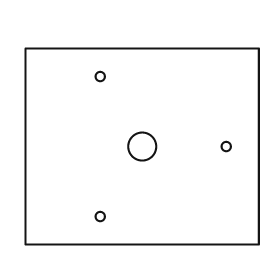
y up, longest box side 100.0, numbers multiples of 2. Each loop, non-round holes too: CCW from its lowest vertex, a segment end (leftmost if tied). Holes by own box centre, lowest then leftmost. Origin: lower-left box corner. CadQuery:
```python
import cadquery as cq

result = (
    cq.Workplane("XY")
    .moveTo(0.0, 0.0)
    .lineTo(100.0, 0.0)
    .lineTo(100.0, 84.0)
    .lineTo(0.0, 84.0)
    .close()
    .moveTo(32.0, 12.0)
    .circle(2.0)
    .moveTo(50.0, 42.0)
    .circle(6.0)
    .moveTo(86.0, 42.0)
    .circle(2.0)
    .moveTo(32.0, 72.0)
    .circle(2.0)
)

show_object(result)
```